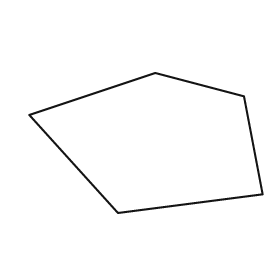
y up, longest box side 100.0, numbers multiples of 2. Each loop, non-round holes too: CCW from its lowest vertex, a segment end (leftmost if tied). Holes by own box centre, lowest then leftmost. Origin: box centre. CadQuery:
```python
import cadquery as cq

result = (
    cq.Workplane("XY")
    .moveTo(-12.0, -30.0)
    .lineTo(50.0, -22.0)
    .lineTo(42.0, 20.0)
    .lineTo(4.0, 30.0)
    .lineTo(-50.0, 12.0)
    .close()
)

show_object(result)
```